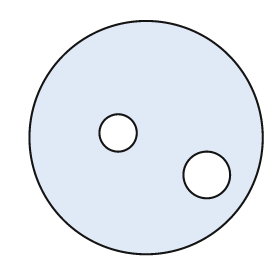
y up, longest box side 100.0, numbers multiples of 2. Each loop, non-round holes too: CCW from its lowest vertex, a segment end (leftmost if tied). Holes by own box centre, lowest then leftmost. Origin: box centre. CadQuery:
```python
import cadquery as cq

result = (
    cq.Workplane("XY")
    .moveTo(0.0, 0.0)
    .circle(50.0)
    .moveTo(26.0, -16.0)
    .circle(10.0)
    .moveTo(-12.0, 2.0)
    .circle(8.0)
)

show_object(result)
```